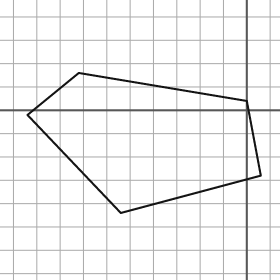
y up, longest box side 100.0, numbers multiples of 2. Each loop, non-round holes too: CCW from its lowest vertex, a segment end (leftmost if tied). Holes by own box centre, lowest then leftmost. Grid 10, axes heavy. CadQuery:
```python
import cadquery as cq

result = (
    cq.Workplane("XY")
    .moveTo(-54.0, -44.0)
    .lineTo(6.0, -28.0)
    .lineTo(0.0, 4.0)
    .lineTo(-72.0, 16.0)
    .lineTo(-94.0, -2.0)
    .close()
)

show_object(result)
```